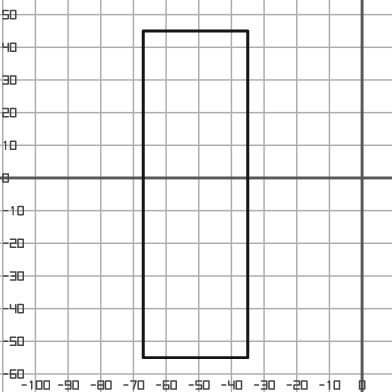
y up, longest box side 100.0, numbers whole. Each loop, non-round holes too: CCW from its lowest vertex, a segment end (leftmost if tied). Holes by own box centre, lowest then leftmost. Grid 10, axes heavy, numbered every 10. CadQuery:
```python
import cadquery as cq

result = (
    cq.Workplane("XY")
    .moveTo(-67.0, -55.0)
    .lineTo(-35.0, -55.0)
    .lineTo(-35.0, 45.0)
    .lineTo(-67.0, 45.0)
    .close()
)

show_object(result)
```